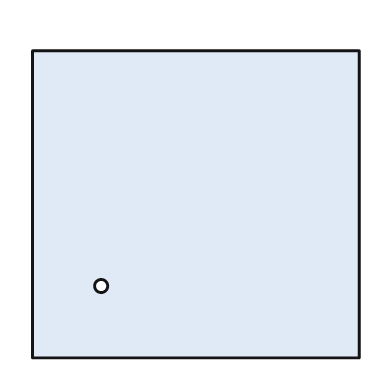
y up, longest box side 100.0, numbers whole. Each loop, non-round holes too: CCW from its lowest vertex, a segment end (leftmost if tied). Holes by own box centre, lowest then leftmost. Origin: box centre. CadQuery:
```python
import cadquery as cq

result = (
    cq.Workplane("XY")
    .moveTo(-50.0, -47.0)
    .lineTo(50.0, -47.0)
    .lineTo(50.0, 47.0)
    .lineTo(-50.0, 47.0)
    .close()
    .moveTo(-29.0, -25.0)
    .circle(2.0)
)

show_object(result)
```